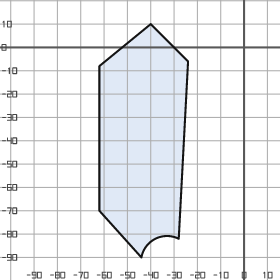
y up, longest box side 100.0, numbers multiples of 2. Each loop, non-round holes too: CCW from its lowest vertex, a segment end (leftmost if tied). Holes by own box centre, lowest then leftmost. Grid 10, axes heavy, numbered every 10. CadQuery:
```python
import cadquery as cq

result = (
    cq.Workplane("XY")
    .moveTo(-44.0, -90.0)
    .threePointArc((-38.0, -82.0), (-28.0, -82.0))
    .lineTo(-24.0, -6.0)
    .lineTo(-40.0, 10.0)
    .lineTo(-62.0, -8.0)
    .lineTo(-62.0, -70.0)
    .close()
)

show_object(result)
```